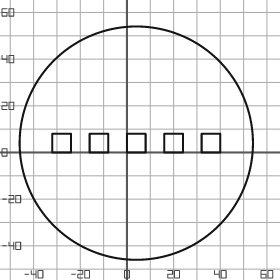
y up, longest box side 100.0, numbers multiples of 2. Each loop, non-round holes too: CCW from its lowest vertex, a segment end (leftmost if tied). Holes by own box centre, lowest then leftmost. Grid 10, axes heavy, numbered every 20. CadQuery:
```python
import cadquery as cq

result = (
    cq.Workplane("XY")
    .moveTo(4.0, 4.0)
    .circle(50.0)
    .moveTo(-32.0, 0.0)
    .lineTo(-24.0, 0.0)
    .lineTo(-24.0, 8.0)
    .lineTo(-32.0, 8.0)
    .close()
    .moveTo(-16.0, 0.0)
    .lineTo(-8.0, 0.0)
    .lineTo(-8.0, 8.0)
    .lineTo(-16.0, 8.0)
    .close()
    .moveTo(0.0, 0.0)
    .lineTo(8.0, 0.0)
    .lineTo(8.0, 8.0)
    .lineTo(0.0, 8.0)
    .close()
    .moveTo(16.0, 0.0)
    .lineTo(24.0, 0.0)
    .lineTo(24.0, 8.0)
    .lineTo(16.0, 8.0)
    .close()
    .moveTo(32.0, 0.0)
    .lineTo(40.0, 0.0)
    .lineTo(40.0, 8.0)
    .lineTo(32.0, 8.0)
    .close()
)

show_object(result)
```